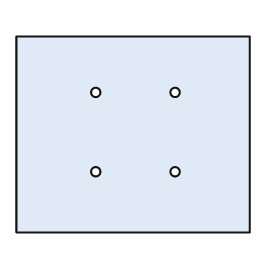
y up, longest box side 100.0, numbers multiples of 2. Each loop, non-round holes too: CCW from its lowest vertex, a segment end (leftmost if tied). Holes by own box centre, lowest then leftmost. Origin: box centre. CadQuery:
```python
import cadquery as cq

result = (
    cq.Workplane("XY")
    .moveTo(-50.0, -42.0)
    .lineTo(50.0, -42.0)
    .lineTo(50.0, 42.0)
    .lineTo(-50.0, 42.0)
    .close()
    .moveTo(-16.0, -16.0)
    .circle(2.0)
    .moveTo(18.0, -16.0)
    .circle(2.0)
    .moveTo(-16.0, 18.0)
    .circle(2.0)
    .moveTo(18.0, 18.0)
    .circle(2.0)
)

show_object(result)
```